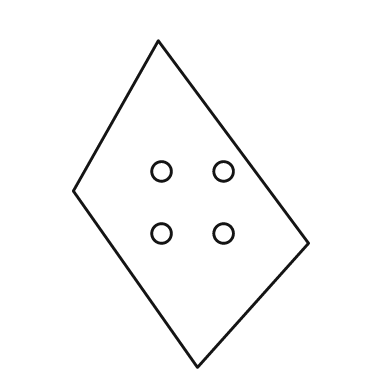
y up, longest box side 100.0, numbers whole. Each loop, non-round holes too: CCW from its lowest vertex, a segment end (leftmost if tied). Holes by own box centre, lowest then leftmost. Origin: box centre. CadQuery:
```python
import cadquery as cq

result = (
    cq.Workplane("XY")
    .moveTo(2.0, -50.0)
    .lineTo(36.0, -12.0)
    .lineTo(-10.0, 50.0)
    .lineTo(-36.0, 4.0)
    .close()
    .moveTo(-9.0, -9.0)
    .circle(3.0)
    .moveTo(10.0, -9.0)
    .circle(3.0)
    .moveTo(-9.0, 10.0)
    .circle(3.0)
    .moveTo(10.0, 10.0)
    .circle(3.0)
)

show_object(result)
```